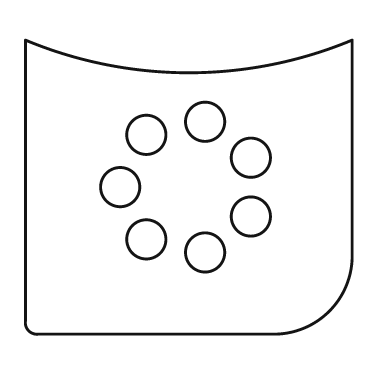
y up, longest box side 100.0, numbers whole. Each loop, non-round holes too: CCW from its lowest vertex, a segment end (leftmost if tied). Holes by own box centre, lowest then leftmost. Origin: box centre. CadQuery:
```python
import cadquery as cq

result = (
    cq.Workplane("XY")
    .moveTo(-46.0, -45.0)
    .lineTo(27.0, -45.0)
    .threePointArc((43.0, -38.0), (50.0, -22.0))
    .lineTo(50.0, 45.0)
    .threePointArc((0.0, 35.0), (-50.0, 45.0))
    .lineTo(-50.0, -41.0)
    .threePointArc((-49.0, -44.0), (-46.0, -45.0))
    .close()
    .moveTo(5.0, -20.0)
    .circle(6.0)
    .moveTo(-13.0, -16.0)
    .circle(6.0)
    .moveTo(19.0, -9.0)
    .circle(6.0)
    .moveTo(-21.0, 0.0)
    .circle(6.0)
    .moveTo(19.0, 9.0)
    .circle(6.0)
    .moveTo(-13.0, 16.0)
    .circle(6.0)
    .moveTo(5.0, 20.0)
    .circle(6.0)
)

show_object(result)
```